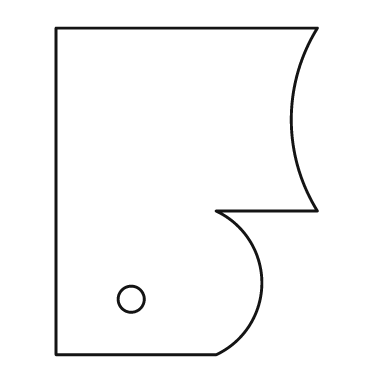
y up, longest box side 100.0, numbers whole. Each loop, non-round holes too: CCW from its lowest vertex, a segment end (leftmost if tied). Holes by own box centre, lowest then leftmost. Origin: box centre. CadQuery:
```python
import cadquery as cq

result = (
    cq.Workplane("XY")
    .moveTo(-40.0, -50.0)
    .lineTo(9.0, -50.0)
    .threePointArc((23.0, -28.0), (9.0, -6.0))
    .lineTo(40.0, -6.0)
    .threePointArc((32.0, 22.0), (40.0, 50.0))
    .lineTo(-40.0, 50.0)
    .close()
    .moveTo(-17.0, -33.0)
    .circle(4.0)
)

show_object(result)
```